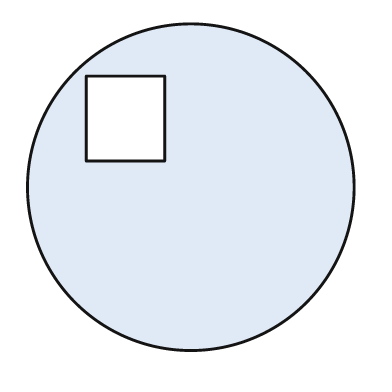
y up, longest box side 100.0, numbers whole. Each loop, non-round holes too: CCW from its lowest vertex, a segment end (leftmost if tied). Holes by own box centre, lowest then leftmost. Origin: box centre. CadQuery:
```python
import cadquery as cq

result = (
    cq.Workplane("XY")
    .moveTo(0.0, 0.0)
    .circle(50.0)
    .moveTo(-32.0, 8.0)
    .lineTo(-8.0, 8.0)
    .lineTo(-8.0, 34.0)
    .lineTo(-32.0, 34.0)
    .close()
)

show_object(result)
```